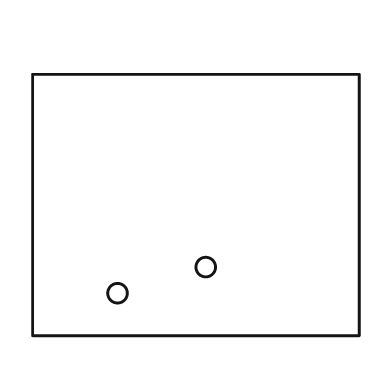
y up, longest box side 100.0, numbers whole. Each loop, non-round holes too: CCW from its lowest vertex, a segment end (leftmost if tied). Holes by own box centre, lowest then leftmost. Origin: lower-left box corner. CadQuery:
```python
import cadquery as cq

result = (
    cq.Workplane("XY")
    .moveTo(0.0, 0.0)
    .lineTo(100.0, 0.0)
    .lineTo(100.0, 80.0)
    .lineTo(0.0, 80.0)
    .close()
    .moveTo(26.0, 13.0)
    .circle(3.0)
    .moveTo(53.0, 21.0)
    .circle(3.0)
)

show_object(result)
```